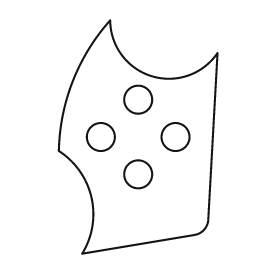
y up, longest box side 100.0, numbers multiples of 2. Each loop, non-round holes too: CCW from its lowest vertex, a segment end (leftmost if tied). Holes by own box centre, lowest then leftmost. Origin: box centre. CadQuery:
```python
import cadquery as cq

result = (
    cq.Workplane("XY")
    .moveTo(-24.0, -50.0)
    .lineTo(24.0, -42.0)
    .threePointArc((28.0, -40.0), (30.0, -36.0))
    .lineTo(34.0, 36.0)
    .threePointArc((6.0, 26.0), (-12.0, 50.0))
    .threePointArc((-28.0, 24.0), (-34.0, -6.0))
    .threePointArc((-20.0, -26.0), (-24.0, -50.0))
    .close()
    .moveTo(0.0, -16.0)
    .circle(6.0)
    .moveTo(-16.0, 0.0)
    .circle(6.0)
    .moveTo(16.0, 0.0)
    .circle(6.0)
    .moveTo(0.0, 16.0)
    .circle(6.0)
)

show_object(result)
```